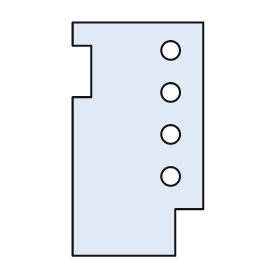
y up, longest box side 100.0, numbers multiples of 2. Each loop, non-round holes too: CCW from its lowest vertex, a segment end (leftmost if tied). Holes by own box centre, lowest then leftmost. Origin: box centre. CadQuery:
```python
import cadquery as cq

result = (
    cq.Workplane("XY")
    .moveTo(-28.0, -50.0)
    .lineTo(16.0, -50.0)
    .lineTo(16.0, -30.0)
    .lineTo(28.0, -30.0)
    .lineTo(28.0, 50.0)
    .lineTo(-28.0, 50.0)
    .lineTo(-28.0, 40.0)
    .lineTo(-20.0, 40.0)
    .lineTo(-20.0, 18.0)
    .lineTo(-28.0, 18.0)
    .close()
    .moveTo(14.0, -16.0)
    .circle(4.0)
    .moveTo(14.0, 2.0)
    .circle(4.0)
    .moveTo(14.0, 20.0)
    .circle(4.0)
    .moveTo(14.0, 38.0)
    .circle(4.0)
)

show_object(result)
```